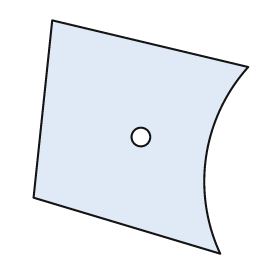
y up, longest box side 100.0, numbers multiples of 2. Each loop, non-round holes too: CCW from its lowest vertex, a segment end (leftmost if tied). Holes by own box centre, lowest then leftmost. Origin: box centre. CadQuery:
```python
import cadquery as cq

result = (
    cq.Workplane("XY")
    .moveTo(34.0, -50.0)
    .threePointArc((28.0, -8.0), (46.0, 30.0))
    .lineTo(-38.0, 50.0)
    .lineTo(-46.0, -26.0)
    .close()
    .moveTo(0.0, 0.0)
    .circle(4.0)
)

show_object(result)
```